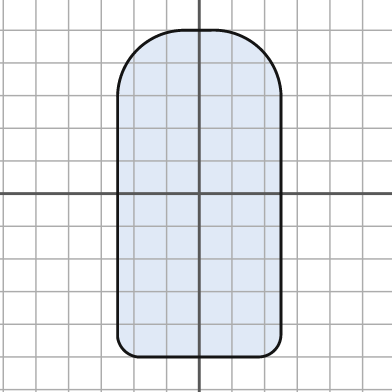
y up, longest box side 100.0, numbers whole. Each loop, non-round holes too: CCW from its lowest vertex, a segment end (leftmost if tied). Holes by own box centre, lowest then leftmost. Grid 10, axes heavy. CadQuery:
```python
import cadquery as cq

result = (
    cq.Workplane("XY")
    .moveTo(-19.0, -50.0)
    .lineTo(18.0, -50.0)
    .threePointArc((23.0, -48.0), (25.0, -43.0))
    .lineTo(25.0, 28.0)
    .threePointArc((19.0, 44.0), (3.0, 50.0))
    .lineTo(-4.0, 50.0)
    .threePointArc((-19.0, 44.0), (-25.0, 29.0))
    .lineTo(-25.0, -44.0)
    .threePointArc((-23.0, -48.0), (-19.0, -50.0))
    .close()
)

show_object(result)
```